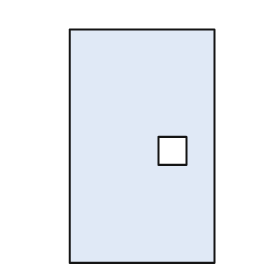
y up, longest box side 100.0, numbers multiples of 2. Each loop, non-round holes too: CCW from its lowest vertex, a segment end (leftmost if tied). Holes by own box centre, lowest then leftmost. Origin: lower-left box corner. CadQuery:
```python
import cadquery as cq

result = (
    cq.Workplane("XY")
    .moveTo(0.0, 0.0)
    .lineTo(62.0, 0.0)
    .lineTo(62.0, 100.0)
    .lineTo(0.0, 100.0)
    .close()
    .moveTo(38.0, 42.0)
    .lineTo(50.0, 42.0)
    .lineTo(50.0, 54.0)
    .lineTo(38.0, 54.0)
    .close()
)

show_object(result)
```